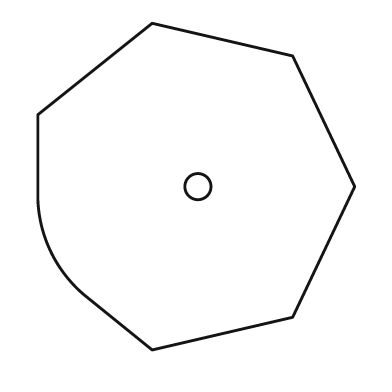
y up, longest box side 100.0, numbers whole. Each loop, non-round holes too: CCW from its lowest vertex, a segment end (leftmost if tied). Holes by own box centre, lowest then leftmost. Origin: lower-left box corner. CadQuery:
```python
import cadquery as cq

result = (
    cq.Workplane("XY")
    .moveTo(35.0, 0.0)
    .lineTo(78.0, 10.0)
    .lineTo(97.0, 50.0)
    .lineTo(78.0, 90.0)
    .lineTo(35.0, 100.0)
    .lineTo(0.0, 72.0)
    .lineTo(0.0, 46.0)
    .threePointArc((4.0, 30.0), (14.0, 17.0))
    .close()
    .moveTo(49.0, 50.0)
    .circle(4.0)
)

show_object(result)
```